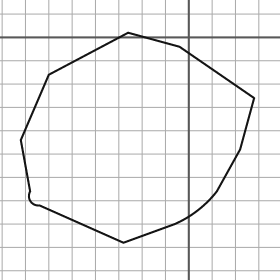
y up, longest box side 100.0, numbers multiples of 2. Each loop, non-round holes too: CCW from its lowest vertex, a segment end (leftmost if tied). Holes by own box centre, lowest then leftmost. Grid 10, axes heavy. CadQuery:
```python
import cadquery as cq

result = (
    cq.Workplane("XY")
    .moveTo(-28.0, -88.0)
    .lineTo(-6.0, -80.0)
    .threePointArc((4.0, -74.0), (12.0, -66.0))
    .lineTo(22.0, -48.0)
    .lineTo(28.0, -26.0)
    .lineTo(-4.0, -4.0)
    .lineTo(-26.0, 2.0)
    .lineTo(-60.0, -16.0)
    .lineTo(-72.0, -44.0)
    .lineTo(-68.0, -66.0)
    .threePointArc((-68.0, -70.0), (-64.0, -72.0))
    .close()
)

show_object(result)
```